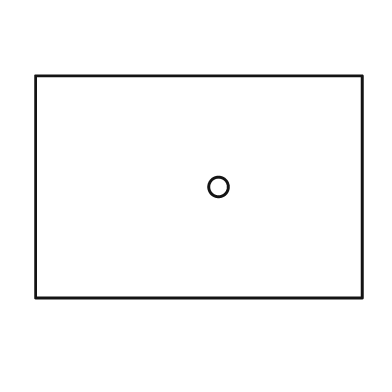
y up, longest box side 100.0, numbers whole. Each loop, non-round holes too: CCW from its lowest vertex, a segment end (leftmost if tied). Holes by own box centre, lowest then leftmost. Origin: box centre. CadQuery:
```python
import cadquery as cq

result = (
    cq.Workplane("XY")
    .moveTo(-50.0, -34.0)
    .lineTo(50.0, -34.0)
    .lineTo(50.0, 34.0)
    .lineTo(-50.0, 34.0)
    .close()
    .moveTo(6.0, 0.0)
    .circle(3.0)
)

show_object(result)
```